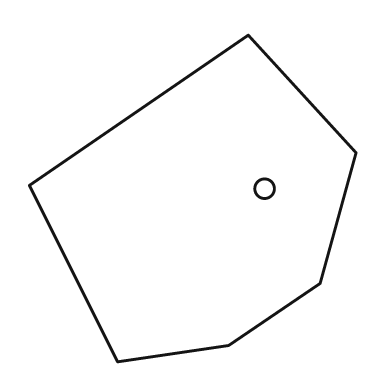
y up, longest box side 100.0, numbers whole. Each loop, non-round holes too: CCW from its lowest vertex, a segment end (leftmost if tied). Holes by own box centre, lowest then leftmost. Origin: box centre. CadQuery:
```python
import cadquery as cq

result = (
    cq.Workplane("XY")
    .moveTo(-23.0, -50.0)
    .lineTo(11.0, -45.0)
    .lineTo(39.0, -26.0)
    .lineTo(50.0, 14.0)
    .lineTo(17.0, 50.0)
    .lineTo(-50.0, 4.0)
    .close()
    .moveTo(22.0, 3.0)
    .circle(3.0)
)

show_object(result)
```